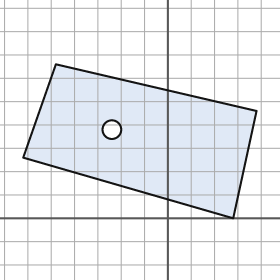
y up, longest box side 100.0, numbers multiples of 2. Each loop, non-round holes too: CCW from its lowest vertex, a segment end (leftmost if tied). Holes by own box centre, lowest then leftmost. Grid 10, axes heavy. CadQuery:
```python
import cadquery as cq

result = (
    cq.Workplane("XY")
    .moveTo(28.0, 0.0)
    .lineTo(38.0, 46.0)
    .lineTo(-48.0, 66.0)
    .lineTo(-62.0, 26.0)
    .close()
    .moveTo(-24.0, 38.0)
    .circle(4.0)
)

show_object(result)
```